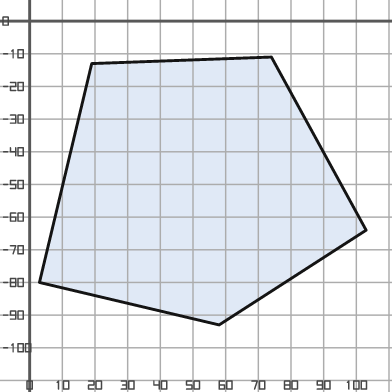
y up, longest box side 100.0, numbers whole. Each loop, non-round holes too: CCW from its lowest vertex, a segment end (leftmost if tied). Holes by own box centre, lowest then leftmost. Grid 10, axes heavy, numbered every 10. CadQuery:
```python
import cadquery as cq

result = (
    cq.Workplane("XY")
    .moveTo(58.0, -93.0)
    .lineTo(103.0, -64.0)
    .lineTo(74.0, -11.0)
    .lineTo(19.0, -13.0)
    .lineTo(3.0, -80.0)
    .close()
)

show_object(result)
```